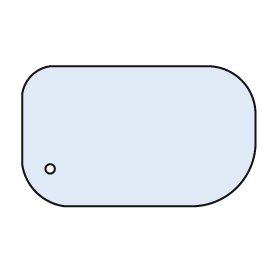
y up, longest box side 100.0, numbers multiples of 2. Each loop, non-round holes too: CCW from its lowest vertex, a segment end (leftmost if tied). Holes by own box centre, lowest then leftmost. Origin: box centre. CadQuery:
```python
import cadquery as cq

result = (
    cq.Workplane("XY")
    .moveTo(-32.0, -30.0)
    .lineTo(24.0, -30.0)
    .threePointArc((42.0, -22.0), (50.0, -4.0))
    .lineTo(50.0, 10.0)
    .threePointArc((44.0, 24.0), (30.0, 30.0))
    .lineTo(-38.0, 30.0)
    .threePointArc((-46.0, 26.0), (-50.0, 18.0))
    .lineTo(-50.0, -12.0)
    .threePointArc((-44.0, -24.0), (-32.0, -30.0))
    .close()
    .moveTo(-38.0, -14.0)
    .circle(2.0)
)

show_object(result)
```